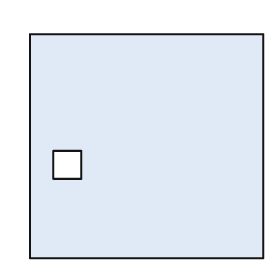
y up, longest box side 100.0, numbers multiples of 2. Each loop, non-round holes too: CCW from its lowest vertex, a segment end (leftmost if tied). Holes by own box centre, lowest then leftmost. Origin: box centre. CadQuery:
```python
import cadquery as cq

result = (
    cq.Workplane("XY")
    .moveTo(-50.0, -48.0)
    .lineTo(50.0, -48.0)
    .lineTo(50.0, 48.0)
    .lineTo(-50.0, 48.0)
    .close()
    .moveTo(-40.0, -14.0)
    .lineTo(-28.0, -14.0)
    .lineTo(-28.0, -2.0)
    .lineTo(-40.0, -2.0)
    .close()
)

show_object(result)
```